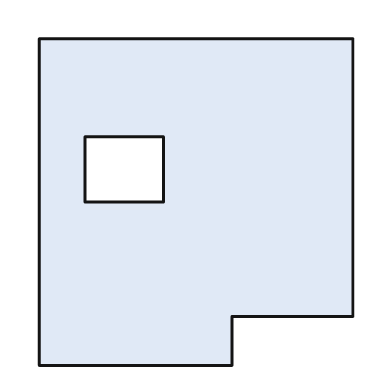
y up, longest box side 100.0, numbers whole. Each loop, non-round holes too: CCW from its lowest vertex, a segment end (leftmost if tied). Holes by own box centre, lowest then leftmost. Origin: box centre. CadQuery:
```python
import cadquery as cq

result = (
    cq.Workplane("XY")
    .moveTo(-48.0, -50.0)
    .lineTo(11.0, -50.0)
    .lineTo(11.0, -35.0)
    .lineTo(48.0, -35.0)
    .lineTo(48.0, 50.0)
    .lineTo(-48.0, 50.0)
    .close()
    .moveTo(-34.0, 0.0)
    .lineTo(-10.0, 0.0)
    .lineTo(-10.0, 20.0)
    .lineTo(-34.0, 20.0)
    .close()
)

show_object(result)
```